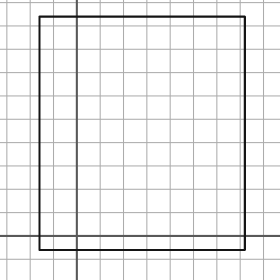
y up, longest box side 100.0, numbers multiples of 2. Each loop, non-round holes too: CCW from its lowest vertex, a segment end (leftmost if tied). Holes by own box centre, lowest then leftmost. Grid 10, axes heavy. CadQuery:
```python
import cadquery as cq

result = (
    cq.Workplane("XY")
    .moveTo(-16.0, -6.0)
    .lineTo(72.0, -6.0)
    .lineTo(72.0, 94.0)
    .lineTo(-16.0, 94.0)
    .close()
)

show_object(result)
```